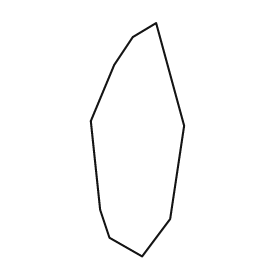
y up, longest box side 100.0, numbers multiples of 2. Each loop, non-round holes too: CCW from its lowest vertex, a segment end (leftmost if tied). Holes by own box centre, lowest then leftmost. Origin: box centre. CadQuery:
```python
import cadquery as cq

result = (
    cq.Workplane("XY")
    .moveTo(2.0, -50.0)
    .lineTo(14.0, -34.0)
    .lineTo(20.0, 6.0)
    .lineTo(8.0, 50.0)
    .lineTo(-2.0, 44.0)
    .lineTo(-10.0, 32.0)
    .lineTo(-20.0, 8.0)
    .lineTo(-16.0, -30.0)
    .lineTo(-12.0, -42.0)
    .close()
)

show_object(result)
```